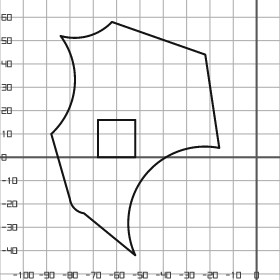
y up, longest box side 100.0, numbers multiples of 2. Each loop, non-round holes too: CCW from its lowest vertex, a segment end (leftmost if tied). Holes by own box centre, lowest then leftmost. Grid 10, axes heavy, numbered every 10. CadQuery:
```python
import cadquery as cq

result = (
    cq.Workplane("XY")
    .moveTo(-52.0, -42.0)
    .threePointArc((-48.0, -8.0), (-16.0, 4.0))
    .lineTo(-22.0, 44.0)
    .lineTo(-62.0, 58.0)
    .threePointArc((-72.0, 52.0), (-84.0, 52.0))
    .threePointArc((-78.0, 30.0), (-88.0, 10.0))
    .lineTo(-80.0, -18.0)
    .threePointArc((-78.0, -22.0), (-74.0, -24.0))
    .close()
    .moveTo(-68.0, 0.0)
    .lineTo(-52.0, 0.0)
    .lineTo(-52.0, 16.0)
    .lineTo(-68.0, 16.0)
    .close()
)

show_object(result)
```